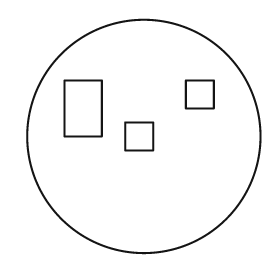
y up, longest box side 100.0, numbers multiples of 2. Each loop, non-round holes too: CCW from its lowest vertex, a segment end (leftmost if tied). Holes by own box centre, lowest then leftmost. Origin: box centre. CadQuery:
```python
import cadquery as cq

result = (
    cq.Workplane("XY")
    .moveTo(0.0, 0.0)
    .circle(50.0)
    .moveTo(-8.0, -6.0)
    .lineTo(4.0, -6.0)
    .lineTo(4.0, 6.0)
    .lineTo(-8.0, 6.0)
    .close()
    .moveTo(-34.0, 0.0)
    .lineTo(-18.0, 0.0)
    .lineTo(-18.0, 24.0)
    .lineTo(-34.0, 24.0)
    .close()
    .moveTo(18.0, 12.0)
    .lineTo(30.0, 12.0)
    .lineTo(30.0, 24.0)
    .lineTo(18.0, 24.0)
    .close()
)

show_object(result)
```